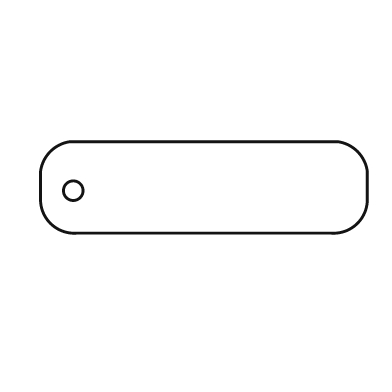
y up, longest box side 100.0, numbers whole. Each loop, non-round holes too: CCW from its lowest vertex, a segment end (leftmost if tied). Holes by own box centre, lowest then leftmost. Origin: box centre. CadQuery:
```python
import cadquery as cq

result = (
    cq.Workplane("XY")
    .moveTo(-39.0, -14.0)
    .lineTo(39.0, -14.0)
    .threePointArc((47.0, -11.0), (50.0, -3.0))
    .lineTo(50.0, 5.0)
    .threePointArc((47.0, 11.0), (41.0, 14.0))
    .lineTo(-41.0, 14.0)
    .threePointArc((-47.0, 11.0), (-50.0, 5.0))
    .lineTo(-50.0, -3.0)
    .threePointArc((-47.0, -11.0), (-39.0, -14.0))
    .close()
    .moveTo(-40.0, -1.0)
    .circle(3.0)
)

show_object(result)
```